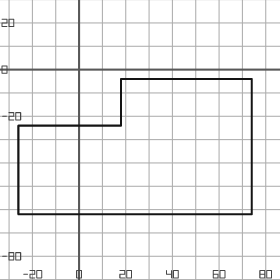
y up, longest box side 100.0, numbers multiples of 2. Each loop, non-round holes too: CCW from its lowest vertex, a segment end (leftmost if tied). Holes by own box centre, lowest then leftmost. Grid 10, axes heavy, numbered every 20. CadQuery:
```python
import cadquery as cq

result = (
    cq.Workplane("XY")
    .moveTo(-26.0, -62.0)
    .lineTo(74.0, -62.0)
    .lineTo(74.0, -4.0)
    .lineTo(18.0, -4.0)
    .lineTo(18.0, -24.0)
    .lineTo(-26.0, -24.0)
    .close()
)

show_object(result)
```